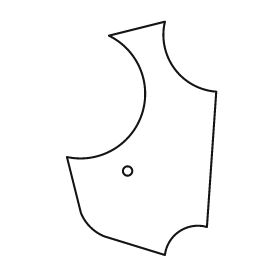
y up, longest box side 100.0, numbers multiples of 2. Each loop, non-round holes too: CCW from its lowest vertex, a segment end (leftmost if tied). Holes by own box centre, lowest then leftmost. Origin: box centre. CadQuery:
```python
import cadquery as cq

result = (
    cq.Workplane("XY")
    .moveTo(10.0, -50.0)
    .threePointArc((16.0, -40.0), (28.0, -38.0))
    .lineTo(32.0, 20.0)
    .threePointArc((14.0, 30.0), (10.0, 50.0))
    .lineTo(-14.0, 44.0)
    .threePointArc((0.0, 10.0), (-32.0, -8.0))
    .lineTo(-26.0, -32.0)
    .threePointArc((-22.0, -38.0), (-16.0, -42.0))
    .close()
    .moveTo(-6.0, -14.0)
    .circle(2.0)
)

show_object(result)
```